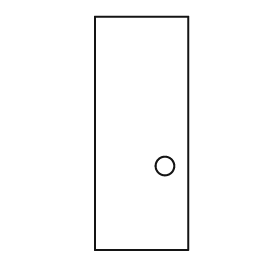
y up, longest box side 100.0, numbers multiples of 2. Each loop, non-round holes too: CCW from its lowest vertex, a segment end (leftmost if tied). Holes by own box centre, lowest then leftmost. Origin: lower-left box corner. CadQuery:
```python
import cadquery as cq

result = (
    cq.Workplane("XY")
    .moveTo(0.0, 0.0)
    .lineTo(40.0, 0.0)
    .lineTo(40.0, 100.0)
    .lineTo(0.0, 100.0)
    .close()
    .moveTo(30.0, 36.0)
    .circle(4.0)
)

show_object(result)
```